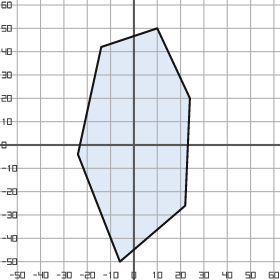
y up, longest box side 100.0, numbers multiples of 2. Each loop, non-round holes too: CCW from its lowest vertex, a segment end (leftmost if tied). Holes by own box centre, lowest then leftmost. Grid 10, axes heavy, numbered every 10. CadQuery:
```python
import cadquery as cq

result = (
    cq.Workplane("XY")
    .moveTo(-6.0, -50.0)
    .lineTo(22.0, -26.0)
    .lineTo(24.0, 20.0)
    .lineTo(10.0, 50.0)
    .lineTo(-14.0, 42.0)
    .lineTo(-24.0, -4.0)
    .close()
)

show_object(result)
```